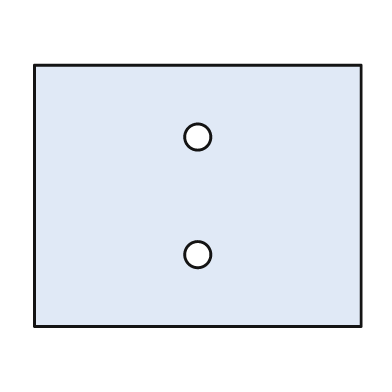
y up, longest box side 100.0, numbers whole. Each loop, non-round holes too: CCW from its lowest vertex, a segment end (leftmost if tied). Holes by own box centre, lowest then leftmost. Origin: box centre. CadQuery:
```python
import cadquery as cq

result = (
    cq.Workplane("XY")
    .moveTo(-50.0, -40.0)
    .lineTo(50.0, -40.0)
    .lineTo(50.0, 40.0)
    .lineTo(-50.0, 40.0)
    .close()
    .moveTo(0.0, -18.0)
    .circle(4.0)
    .moveTo(0.0, 18.0)
    .circle(4.0)
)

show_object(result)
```